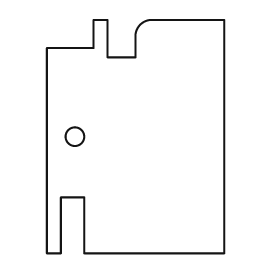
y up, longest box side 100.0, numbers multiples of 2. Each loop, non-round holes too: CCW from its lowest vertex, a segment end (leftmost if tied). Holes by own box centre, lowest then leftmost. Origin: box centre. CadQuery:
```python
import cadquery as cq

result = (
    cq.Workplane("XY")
    .moveTo(-38.0, -50.0)
    .lineTo(-32.0, -50.0)
    .lineTo(-32.0, -26.0)
    .lineTo(-22.0, -26.0)
    .lineTo(-22.0, -50.0)
    .lineTo(38.0, -50.0)
    .lineTo(38.0, 50.0)
    .lineTo(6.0, 50.0)
    .threePointArc((2.0, 48.0), (0.0, 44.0))
    .lineTo(0.0, 34.0)
    .lineTo(-12.0, 34.0)
    .lineTo(-12.0, 50.0)
    .lineTo(-18.0, 50.0)
    .lineTo(-18.0, 38.0)
    .lineTo(-38.0, 38.0)
    .close()
    .moveTo(-26.0, 0.0)
    .circle(4.0)
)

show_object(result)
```